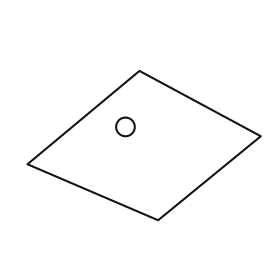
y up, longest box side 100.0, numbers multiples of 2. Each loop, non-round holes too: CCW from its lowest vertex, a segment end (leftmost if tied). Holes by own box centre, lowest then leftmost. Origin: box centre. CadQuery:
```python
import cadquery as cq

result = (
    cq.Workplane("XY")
    .moveTo(6.0, -32.0)
    .lineTo(50.0, 4.0)
    .lineTo(-2.0, 32.0)
    .lineTo(-50.0, -8.0)
    .close()
    .moveTo(-8.0, 8.0)
    .circle(4.0)
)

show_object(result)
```